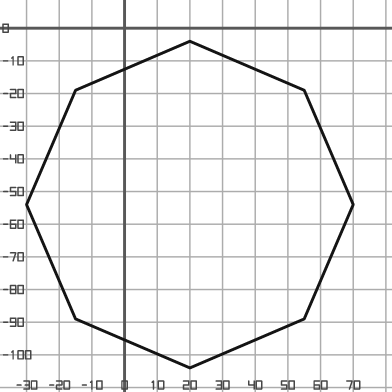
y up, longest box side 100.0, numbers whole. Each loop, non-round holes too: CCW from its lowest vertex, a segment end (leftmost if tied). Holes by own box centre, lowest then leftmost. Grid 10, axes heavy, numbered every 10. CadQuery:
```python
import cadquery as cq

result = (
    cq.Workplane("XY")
    .moveTo(20.0, -104.0)
    .lineTo(55.0, -89.0)
    .lineTo(70.0, -54.0)
    .lineTo(55.0, -19.0)
    .lineTo(20.0, -4.0)
    .lineTo(-15.0, -19.0)
    .lineTo(-30.0, -54.0)
    .lineTo(-15.0, -89.0)
    .close()
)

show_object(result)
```